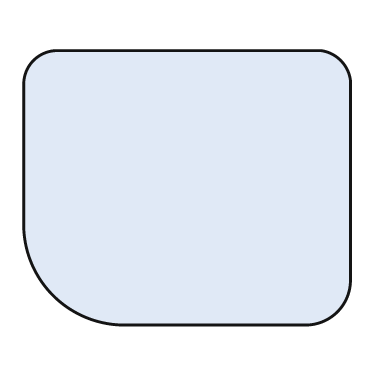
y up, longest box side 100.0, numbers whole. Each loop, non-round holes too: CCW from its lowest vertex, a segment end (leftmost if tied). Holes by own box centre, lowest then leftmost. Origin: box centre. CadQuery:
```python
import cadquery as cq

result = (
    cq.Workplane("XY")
    .moveTo(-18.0, -42.0)
    .lineTo(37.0, -42.0)
    .threePointArc((46.0, -38.0), (50.0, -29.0))
    .lineTo(50.0, 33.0)
    .threePointArc((47.0, 39.0), (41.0, 42.0))
    .lineTo(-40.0, 42.0)
    .threePointArc((-47.0, 39.0), (-50.0, 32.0))
    .lineTo(-50.0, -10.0)
    .threePointArc((-41.0, -33.0), (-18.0, -42.0))
    .close()
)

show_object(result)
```